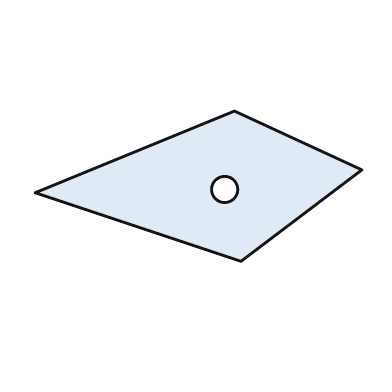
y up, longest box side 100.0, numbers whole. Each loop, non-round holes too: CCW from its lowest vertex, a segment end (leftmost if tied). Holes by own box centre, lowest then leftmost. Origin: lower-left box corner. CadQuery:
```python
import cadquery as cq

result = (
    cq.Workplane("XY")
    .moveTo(63.0, 0.0)
    .lineTo(100.0, 28.0)
    .lineTo(61.0, 46.0)
    .lineTo(0.0, 21.0)
    .close()
    .moveTo(58.0, 22.0)
    .circle(4.0)
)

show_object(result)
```